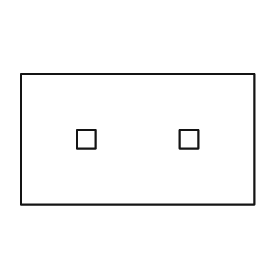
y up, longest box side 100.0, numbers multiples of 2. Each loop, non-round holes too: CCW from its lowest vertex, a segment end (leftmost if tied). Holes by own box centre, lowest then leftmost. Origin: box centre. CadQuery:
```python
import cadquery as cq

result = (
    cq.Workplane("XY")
    .moveTo(-50.0, -28.0)
    .lineTo(50.0, -28.0)
    .lineTo(50.0, 28.0)
    .lineTo(-50.0, 28.0)
    .close()
    .moveTo(-26.0, -4.0)
    .lineTo(-18.0, -4.0)
    .lineTo(-18.0, 4.0)
    .lineTo(-26.0, 4.0)
    .close()
    .moveTo(18.0, -4.0)
    .lineTo(26.0, -4.0)
    .lineTo(26.0, 4.0)
    .lineTo(18.0, 4.0)
    .close()
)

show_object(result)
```